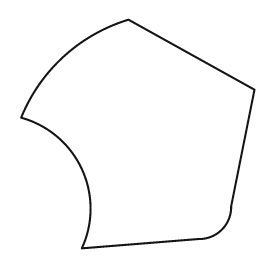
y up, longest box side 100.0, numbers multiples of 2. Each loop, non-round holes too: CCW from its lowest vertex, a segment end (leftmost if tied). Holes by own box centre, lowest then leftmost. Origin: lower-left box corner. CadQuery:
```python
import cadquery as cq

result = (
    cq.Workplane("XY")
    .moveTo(26.0, 0.0)
    .lineTo(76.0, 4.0)
    .threePointArc((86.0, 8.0), (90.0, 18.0))
    .lineTo(100.0, 68.0)
    .lineTo(46.0, 98.0)
    .threePointArc((18.0, 82.0), (0.0, 56.0))
    .threePointArc((26.0, 34.0), (26.0, 0.0))
    .close()
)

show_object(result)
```